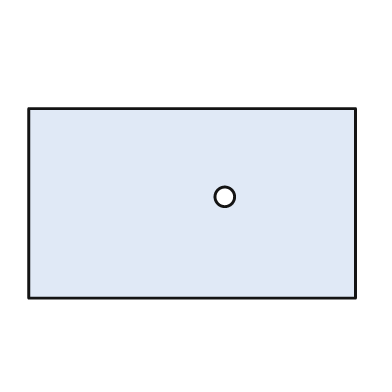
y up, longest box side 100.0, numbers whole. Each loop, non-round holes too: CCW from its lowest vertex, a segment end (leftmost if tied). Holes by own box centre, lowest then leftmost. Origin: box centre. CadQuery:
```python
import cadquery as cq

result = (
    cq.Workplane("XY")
    .moveTo(-50.0, -29.0)
    .lineTo(50.0, -29.0)
    .lineTo(50.0, 29.0)
    .lineTo(-50.0, 29.0)
    .close()
    .moveTo(10.0, 2.0)
    .circle(3.0)
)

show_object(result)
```